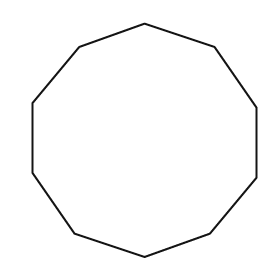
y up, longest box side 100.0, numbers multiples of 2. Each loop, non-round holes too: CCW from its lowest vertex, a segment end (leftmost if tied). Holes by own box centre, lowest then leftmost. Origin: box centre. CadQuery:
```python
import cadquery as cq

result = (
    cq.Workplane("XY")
    .moveTo(0.0, -50.0)
    .lineTo(28.0, -40.0)
    .lineTo(48.0, -16.0)
    .lineTo(48.0, 14.0)
    .lineTo(30.0, 40.0)
    .lineTo(0.0, 50.0)
    .lineTo(-28.0, 40.0)
    .lineTo(-48.0, 16.0)
    .lineTo(-48.0, -14.0)
    .lineTo(-30.0, -40.0)
    .close()
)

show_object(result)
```